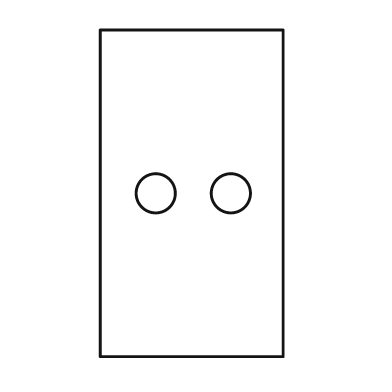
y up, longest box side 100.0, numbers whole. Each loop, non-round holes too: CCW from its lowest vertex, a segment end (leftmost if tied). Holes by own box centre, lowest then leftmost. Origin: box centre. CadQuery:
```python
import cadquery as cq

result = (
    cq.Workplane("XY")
    .moveTo(-28.0, -50.0)
    .lineTo(28.0, -50.0)
    .lineTo(28.0, 50.0)
    .lineTo(-28.0, 50.0)
    .close()
    .moveTo(-11.0, 0.0)
    .circle(6.0)
    .moveTo(12.0, 0.0)
    .circle(6.0)
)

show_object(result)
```